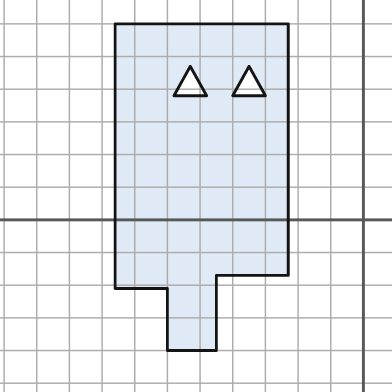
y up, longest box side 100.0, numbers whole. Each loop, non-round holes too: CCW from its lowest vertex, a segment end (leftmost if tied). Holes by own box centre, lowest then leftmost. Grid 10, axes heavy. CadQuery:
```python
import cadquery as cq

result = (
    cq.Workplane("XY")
    .moveTo(-60.0, -40.0)
    .lineTo(-45.0, -40.0)
    .lineTo(-45.0, -17.0)
    .lineTo(-23.0, -17.0)
    .lineTo(-23.0, 60.0)
    .lineTo(-76.0, 60.0)
    .lineTo(-76.0, -21.0)
    .lineTo(-60.0, -21.0)
    .close()
    .moveTo(-58.0, 38.0)
    .lineTo(-48.0, 38.0)
    .lineTo(-53.0, 47.0)
    .close()
    .moveTo(-40.0, 38.0)
    .lineTo(-30.0, 38.0)
    .lineTo(-35.0, 47.0)
    .close()
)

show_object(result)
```